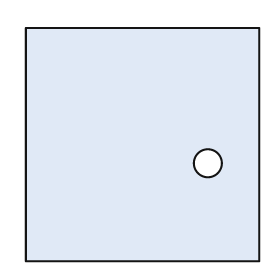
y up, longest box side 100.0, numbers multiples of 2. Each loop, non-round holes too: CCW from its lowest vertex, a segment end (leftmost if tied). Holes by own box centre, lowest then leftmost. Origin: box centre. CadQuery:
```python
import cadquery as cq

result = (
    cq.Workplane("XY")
    .moveTo(-50.0, -50.0)
    .lineTo(50.0, -50.0)
    .lineTo(50.0, 50.0)
    .lineTo(-50.0, 50.0)
    .close()
    .moveTo(28.0, -8.0)
    .circle(6.0)
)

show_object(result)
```